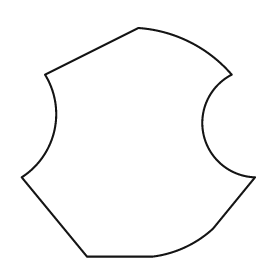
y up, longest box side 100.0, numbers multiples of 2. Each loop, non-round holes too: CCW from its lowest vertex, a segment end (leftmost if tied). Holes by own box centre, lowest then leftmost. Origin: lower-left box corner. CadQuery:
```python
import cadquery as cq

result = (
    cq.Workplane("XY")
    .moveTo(28.0, 0.0)
    .lineTo(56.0, 0.0)
    .threePointArc((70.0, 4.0), (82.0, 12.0))
    .lineTo(100.0, 34.0)
    .threePointArc((78.0, 52.0), (90.0, 78.0))
    .threePointArc((72.0, 92.0), (50.0, 98.0))
    .lineTo(10.0, 78.0)
    .threePointArc((14.0, 54.0), (0.0, 34.0))
    .close()
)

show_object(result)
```